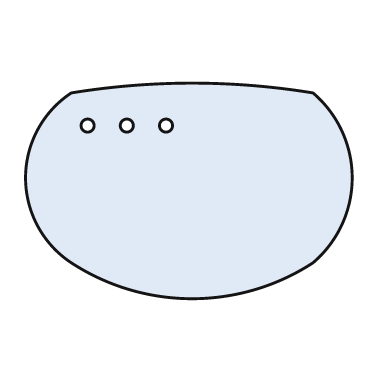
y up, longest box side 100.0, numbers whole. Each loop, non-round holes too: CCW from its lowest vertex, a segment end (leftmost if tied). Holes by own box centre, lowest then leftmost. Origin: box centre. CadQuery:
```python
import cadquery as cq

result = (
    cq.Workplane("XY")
    .moveTo(-36.0, -22.0)
    .threePointArc((1.0, -33.0), (38.0, -22.0))
    .threePointArc((50.0, 4.0), (38.0, 30.0))
    .threePointArc((1.0, 33.0), (-36.0, 30.0))
    .threePointArc((-50.0, 4.0), (-36.0, -22.0))
    .close()
    .moveTo(-31.0, 20.0)
    .circle(2.0)
    .moveTo(-19.0, 20.0)
    .circle(2.0)
    .moveTo(-7.0, 20.0)
    .circle(2.0)
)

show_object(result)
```